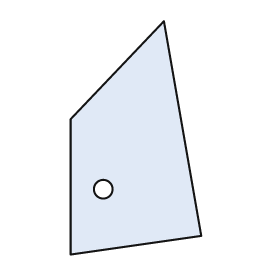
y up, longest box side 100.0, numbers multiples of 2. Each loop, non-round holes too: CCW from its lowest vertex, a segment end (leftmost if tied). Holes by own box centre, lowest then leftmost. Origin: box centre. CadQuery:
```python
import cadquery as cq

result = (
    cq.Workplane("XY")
    .moveTo(-28.0, -50.0)
    .lineTo(28.0, -42.0)
    .lineTo(12.0, 50.0)
    .lineTo(-28.0, 8.0)
    .close()
    .moveTo(-14.0, -22.0)
    .circle(4.0)
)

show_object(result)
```